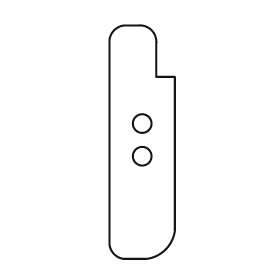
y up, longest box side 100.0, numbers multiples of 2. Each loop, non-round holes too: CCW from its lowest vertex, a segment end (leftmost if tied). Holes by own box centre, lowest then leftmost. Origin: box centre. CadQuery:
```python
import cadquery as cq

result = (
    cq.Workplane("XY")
    .moveTo(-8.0, -50.0)
    .lineTo(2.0, -50.0)
    .threePointArc((10.0, -46.0), (14.0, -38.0))
    .lineTo(14.0, 28.0)
    .lineTo(6.0, 28.0)
    .lineTo(6.0, 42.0)
    .threePointArc((4.0, 48.0), (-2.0, 50.0))
    .lineTo(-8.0, 50.0)
    .threePointArc((-12.0, 48.0), (-14.0, 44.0))
    .lineTo(-14.0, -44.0)
    .threePointArc((-12.0, -48.0), (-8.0, -50.0))
    .close()
    .moveTo(0.0, -6.0)
    .circle(4.0)
    .moveTo(0.0, 8.0)
    .circle(4.0)
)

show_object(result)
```